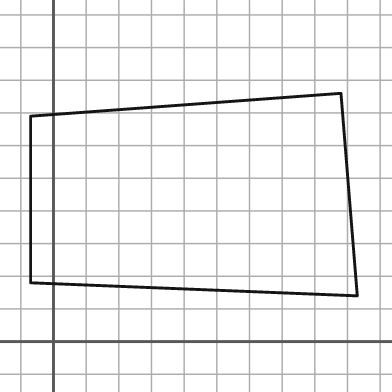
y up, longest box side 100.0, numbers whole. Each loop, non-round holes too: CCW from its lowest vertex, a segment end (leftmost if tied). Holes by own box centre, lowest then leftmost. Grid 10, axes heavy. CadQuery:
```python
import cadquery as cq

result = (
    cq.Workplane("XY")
    .moveTo(93.0, 14.0)
    .lineTo(88.0, 76.0)
    .lineTo(-7.0, 69.0)
    .lineTo(-7.0, 18.0)
    .close()
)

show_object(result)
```